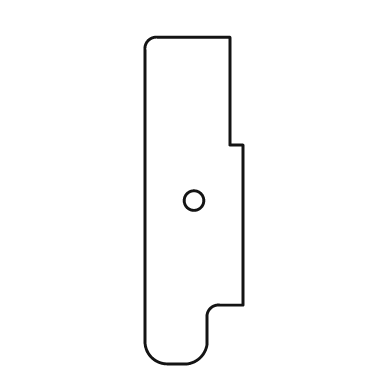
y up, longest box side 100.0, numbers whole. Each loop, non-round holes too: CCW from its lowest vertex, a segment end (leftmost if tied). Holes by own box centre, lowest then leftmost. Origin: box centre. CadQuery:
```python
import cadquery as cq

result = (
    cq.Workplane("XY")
    .moveTo(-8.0, -50.0)
    .lineTo(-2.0, -50.0)
    .threePointArc((2.0, -48.0), (4.0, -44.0))
    .lineTo(4.0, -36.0)
    .threePointArc((5.0, -33.0), (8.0, -32.0))
    .lineTo(15.0, -32.0)
    .lineTo(15.0, 17.0)
    .lineTo(11.0, 17.0)
    .lineTo(11.0, 50.0)
    .lineTo(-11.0, 50.0)
    .threePointArc((-14.0, 49.0), (-15.0, 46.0))
    .lineTo(-15.0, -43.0)
    .threePointArc((-13.0, -48.0), (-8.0, -50.0))
    .close()
    .moveTo(0.0, 0.0)
    .circle(3.0)
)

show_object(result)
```